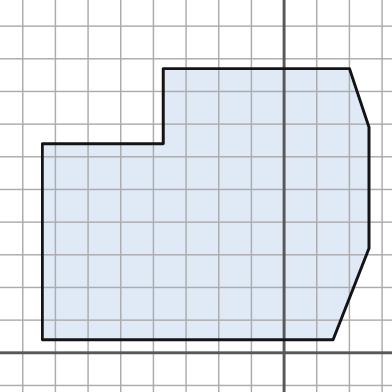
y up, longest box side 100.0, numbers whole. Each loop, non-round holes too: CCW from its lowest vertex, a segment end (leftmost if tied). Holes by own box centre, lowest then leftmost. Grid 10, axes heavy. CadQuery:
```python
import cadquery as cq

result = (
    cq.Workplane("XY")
    .moveTo(-74.0, 4.0)
    .lineTo(15.0, 4.0)
    .lineTo(26.0, 32.0)
    .lineTo(26.0, 69.0)
    .lineTo(20.0, 87.0)
    .lineTo(-37.0, 87.0)
    .lineTo(-37.0, 64.0)
    .lineTo(-74.0, 64.0)
    .close()
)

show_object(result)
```